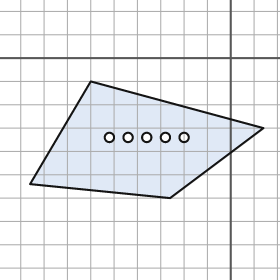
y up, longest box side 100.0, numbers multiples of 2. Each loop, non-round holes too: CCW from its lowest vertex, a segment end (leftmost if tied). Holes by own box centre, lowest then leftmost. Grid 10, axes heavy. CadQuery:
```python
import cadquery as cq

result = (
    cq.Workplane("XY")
    .moveTo(-26.0, -60.0)
    .lineTo(14.0, -30.0)
    .lineTo(-60.0, -10.0)
    .lineTo(-86.0, -54.0)
    .close()
    .moveTo(-52.0, -34.0)
    .circle(2.0)
    .moveTo(-44.0, -34.0)
    .circle(2.0)
    .moveTo(-36.0, -34.0)
    .circle(2.0)
    .moveTo(-28.0, -34.0)
    .circle(2.0)
    .moveTo(-20.0, -34.0)
    .circle(2.0)
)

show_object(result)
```